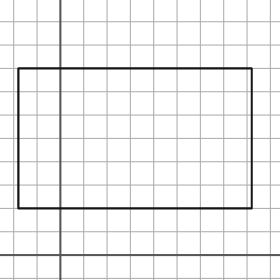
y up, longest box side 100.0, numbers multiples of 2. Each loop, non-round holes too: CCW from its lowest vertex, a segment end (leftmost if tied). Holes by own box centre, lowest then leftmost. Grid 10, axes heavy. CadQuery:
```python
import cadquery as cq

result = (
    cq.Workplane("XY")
    .moveTo(-18.0, 20.0)
    .lineTo(82.0, 20.0)
    .lineTo(82.0, 80.0)
    .lineTo(-18.0, 80.0)
    .close()
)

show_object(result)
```